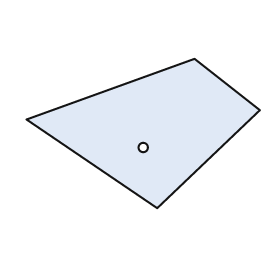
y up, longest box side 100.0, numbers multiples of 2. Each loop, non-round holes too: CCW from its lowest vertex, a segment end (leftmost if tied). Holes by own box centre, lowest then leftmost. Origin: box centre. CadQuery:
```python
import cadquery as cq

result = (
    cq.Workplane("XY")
    .moveTo(6.0, -32.0)
    .lineTo(50.0, 10.0)
    .lineTo(22.0, 32.0)
    .lineTo(-50.0, 6.0)
    .close()
    .moveTo(0.0, -6.0)
    .circle(2.0)
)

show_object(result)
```